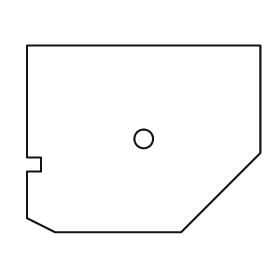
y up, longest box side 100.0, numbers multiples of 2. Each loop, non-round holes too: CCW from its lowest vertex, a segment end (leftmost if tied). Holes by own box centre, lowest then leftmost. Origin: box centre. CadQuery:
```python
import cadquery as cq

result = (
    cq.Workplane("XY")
    .moveTo(-38.0, -40.0)
    .lineTo(16.0, -40.0)
    .lineTo(50.0, -6.0)
    .lineTo(50.0, 40.0)
    .lineTo(-50.0, 40.0)
    .lineTo(-50.0, -8.0)
    .lineTo(-44.0, -8.0)
    .lineTo(-44.0, -14.0)
    .lineTo(-50.0, -14.0)
    .lineTo(-50.0, -34.0)
    .close()
    .moveTo(0.0, 0.0)
    .circle(4.0)
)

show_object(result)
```